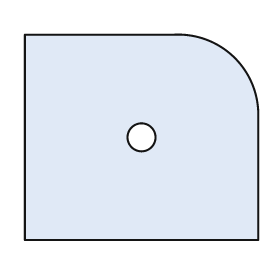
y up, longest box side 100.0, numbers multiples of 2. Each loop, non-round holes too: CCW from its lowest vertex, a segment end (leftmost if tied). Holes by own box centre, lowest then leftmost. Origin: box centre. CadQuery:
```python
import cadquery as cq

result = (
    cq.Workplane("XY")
    .moveTo(-50.0, -44.0)
    .lineTo(50.0, -44.0)
    .lineTo(50.0, 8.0)
    .threePointArc((40.0, 34.0), (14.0, 44.0))
    .lineTo(-50.0, 44.0)
    .close()
    .moveTo(0.0, 0.0)
    .circle(6.0)
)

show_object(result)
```